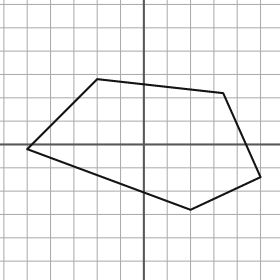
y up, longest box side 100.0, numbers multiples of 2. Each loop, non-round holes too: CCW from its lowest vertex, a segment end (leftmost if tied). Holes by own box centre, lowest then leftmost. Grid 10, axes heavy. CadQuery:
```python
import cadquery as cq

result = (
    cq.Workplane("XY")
    .moveTo(20.0, -28.0)
    .lineTo(50.0, -14.0)
    .lineTo(34.0, 22.0)
    .lineTo(-20.0, 28.0)
    .lineTo(-50.0, -2.0)
    .close()
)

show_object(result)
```